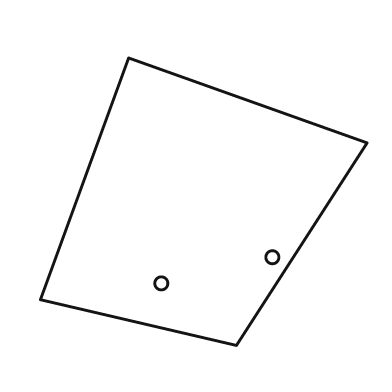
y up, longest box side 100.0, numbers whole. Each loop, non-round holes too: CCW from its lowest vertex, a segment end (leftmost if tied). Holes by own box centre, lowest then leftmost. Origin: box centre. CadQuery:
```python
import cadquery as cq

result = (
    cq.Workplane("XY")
    .moveTo(10.0, -44.0)
    .lineTo(50.0, 18.0)
    .lineTo(-23.0, 44.0)
    .lineTo(-50.0, -30.0)
    .close()
    .moveTo(-13.0, -25.0)
    .circle(2.0)
    .moveTo(21.0, -17.0)
    .circle(2.0)
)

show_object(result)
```